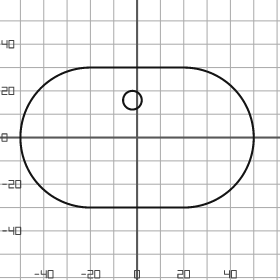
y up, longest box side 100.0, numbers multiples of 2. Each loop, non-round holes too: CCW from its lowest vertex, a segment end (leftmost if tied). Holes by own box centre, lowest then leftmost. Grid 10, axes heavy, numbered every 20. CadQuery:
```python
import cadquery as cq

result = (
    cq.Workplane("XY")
    .moveTo(-20.0, -30.0)
    .lineTo(20.0, -30.0)
    .threePointArc((50.0, 0.0), (20.0, 30.0))
    .lineTo(-20.0, 30.0)
    .threePointArc((-50.0, 0.0), (-20.0, -30.0))
    .close()
    .moveTo(-2.0, 16.0)
    .circle(4.0)
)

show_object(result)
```